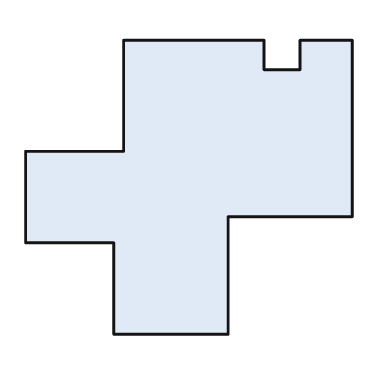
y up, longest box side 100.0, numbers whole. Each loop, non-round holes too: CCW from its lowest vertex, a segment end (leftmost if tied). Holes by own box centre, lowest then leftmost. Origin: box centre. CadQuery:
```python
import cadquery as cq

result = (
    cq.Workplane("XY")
    .moveTo(-23.0, -45.0)
    .lineTo(12.0, -45.0)
    .lineTo(12.0, -9.0)
    .lineTo(50.0, -9.0)
    .lineTo(50.0, 45.0)
    .lineTo(34.0, 45.0)
    .lineTo(34.0, 36.0)
    .lineTo(23.0, 36.0)
    .lineTo(23.0, 45.0)
    .lineTo(-20.0, 45.0)
    .lineTo(-20.0, 11.0)
    .lineTo(-50.0, 11.0)
    .lineTo(-50.0, -17.0)
    .lineTo(-23.0, -17.0)
    .close()
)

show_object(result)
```